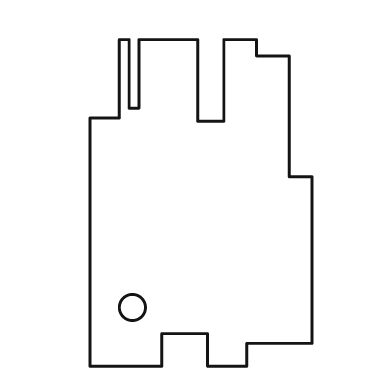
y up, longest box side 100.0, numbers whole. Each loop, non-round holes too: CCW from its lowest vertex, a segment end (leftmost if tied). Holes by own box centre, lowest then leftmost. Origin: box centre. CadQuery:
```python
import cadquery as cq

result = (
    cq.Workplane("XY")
    .moveTo(-34.0, -50.0)
    .lineTo(-12.0, -50.0)
    .lineTo(-12.0, -40.0)
    .lineTo(2.0, -40.0)
    .lineTo(2.0, -50.0)
    .lineTo(14.0, -50.0)
    .lineTo(14.0, -43.0)
    .lineTo(34.0, -43.0)
    .lineTo(34.0, 8.0)
    .lineTo(27.0, 8.0)
    .lineTo(27.0, 45.0)
    .lineTo(17.0, 45.0)
    .lineTo(17.0, 50.0)
    .lineTo(7.0, 50.0)
    .lineTo(7.0, 25.0)
    .lineTo(-1.0, 25.0)
    .lineTo(-1.0, 50.0)
    .lineTo(-19.0, 50.0)
    .lineTo(-19.0, 29.0)
    .lineTo(-22.0, 29.0)
    .lineTo(-22.0, 50.0)
    .lineTo(-25.0, 50.0)
    .lineTo(-25.0, 26.0)
    .lineTo(-34.0, 26.0)
    .close()
    .moveTo(-21.0, -32.0)
    .circle(4.0)
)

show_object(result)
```